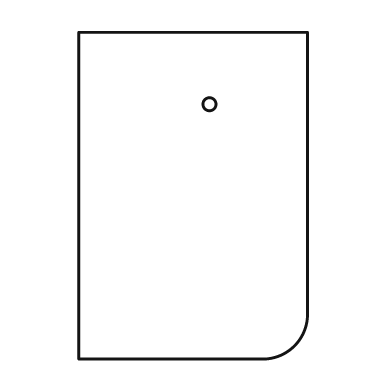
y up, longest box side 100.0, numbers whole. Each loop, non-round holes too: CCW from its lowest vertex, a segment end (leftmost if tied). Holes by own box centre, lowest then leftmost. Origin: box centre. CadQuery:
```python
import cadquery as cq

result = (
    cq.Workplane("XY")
    .moveTo(-35.0, -50.0)
    .lineTo(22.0, -50.0)
    .threePointArc((31.0, -46.0), (35.0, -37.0))
    .lineTo(35.0, 50.0)
    .lineTo(-35.0, 50.0)
    .close()
    .moveTo(5.0, 28.0)
    .circle(2.0)
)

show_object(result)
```